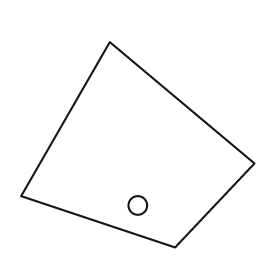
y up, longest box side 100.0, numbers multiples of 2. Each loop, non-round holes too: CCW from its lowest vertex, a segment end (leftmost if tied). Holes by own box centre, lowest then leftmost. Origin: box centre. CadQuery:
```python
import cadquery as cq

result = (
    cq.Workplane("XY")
    .moveTo(16.0, -44.0)
    .lineTo(50.0, -8.0)
    .lineTo(-12.0, 44.0)
    .lineTo(-50.0, -22.0)
    .close()
    .moveTo(0.0, -26.0)
    .circle(4.0)
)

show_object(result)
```